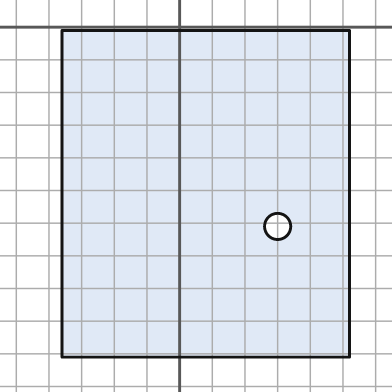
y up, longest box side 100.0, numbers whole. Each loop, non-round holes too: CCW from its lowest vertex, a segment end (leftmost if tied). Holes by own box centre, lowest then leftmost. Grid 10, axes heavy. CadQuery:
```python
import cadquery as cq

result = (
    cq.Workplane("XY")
    .moveTo(-36.0, -101.0)
    .lineTo(52.0, -101.0)
    .lineTo(52.0, -1.0)
    .lineTo(-36.0, -1.0)
    .close()
    .moveTo(30.0, -61.0)
    .circle(4.0)
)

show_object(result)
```